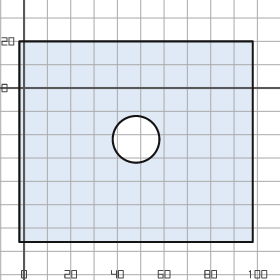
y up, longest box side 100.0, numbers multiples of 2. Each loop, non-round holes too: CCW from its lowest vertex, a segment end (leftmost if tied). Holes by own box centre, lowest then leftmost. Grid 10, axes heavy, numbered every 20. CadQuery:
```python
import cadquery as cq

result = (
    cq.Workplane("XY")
    .moveTo(-2.0, -66.0)
    .lineTo(98.0, -66.0)
    .lineTo(98.0, 20.0)
    .lineTo(-2.0, 20.0)
    .close()
    .moveTo(48.0, -22.0)
    .circle(10.0)
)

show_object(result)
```